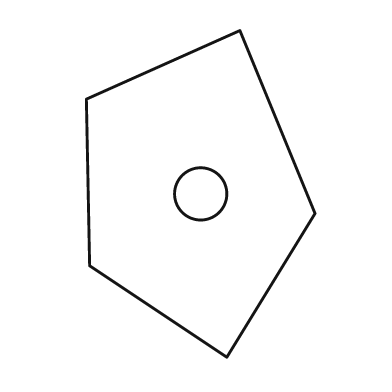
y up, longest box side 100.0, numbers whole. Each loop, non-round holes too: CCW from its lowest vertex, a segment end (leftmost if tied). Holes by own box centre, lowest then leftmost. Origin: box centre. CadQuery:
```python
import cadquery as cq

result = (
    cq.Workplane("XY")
    .moveTo(8.0, -50.0)
    .lineTo(35.0, -6.0)
    .lineTo(12.0, 50.0)
    .lineTo(-35.0, 29.0)
    .lineTo(-34.0, -22.0)
    .close()
    .moveTo(0.0, 0.0)
    .circle(8.0)
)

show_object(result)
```